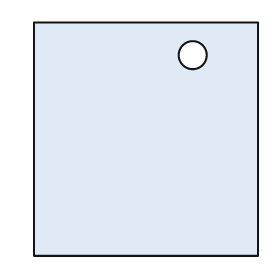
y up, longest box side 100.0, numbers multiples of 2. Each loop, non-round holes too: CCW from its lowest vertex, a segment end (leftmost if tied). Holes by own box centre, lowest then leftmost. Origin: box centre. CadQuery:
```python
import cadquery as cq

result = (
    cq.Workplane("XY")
    .moveTo(-48.0, -50.0)
    .lineTo(48.0, -50.0)
    .lineTo(48.0, 50.0)
    .lineTo(-48.0, 50.0)
    .close()
    .moveTo(20.0, 36.0)
    .circle(6.0)
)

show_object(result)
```